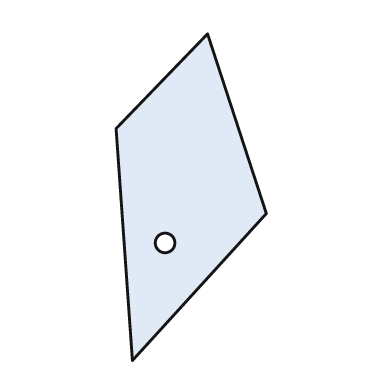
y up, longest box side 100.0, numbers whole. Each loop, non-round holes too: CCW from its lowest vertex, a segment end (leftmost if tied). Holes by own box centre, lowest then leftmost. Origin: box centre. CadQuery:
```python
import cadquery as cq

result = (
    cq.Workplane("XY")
    .moveTo(-18.0, -50.0)
    .lineTo(23.0, -5.0)
    .lineTo(5.0, 50.0)
    .lineTo(-23.0, 21.0)
    .close()
    .moveTo(-8.0, -14.0)
    .circle(3.0)
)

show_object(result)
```